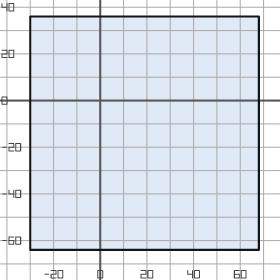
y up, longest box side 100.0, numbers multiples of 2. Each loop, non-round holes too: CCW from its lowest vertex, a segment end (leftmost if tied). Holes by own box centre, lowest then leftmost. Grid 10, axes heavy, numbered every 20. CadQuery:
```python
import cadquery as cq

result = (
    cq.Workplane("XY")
    .moveTo(-30.0, -64.0)
    .lineTo(68.0, -64.0)
    .lineTo(68.0, 36.0)
    .lineTo(-30.0, 36.0)
    .close()
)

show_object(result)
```